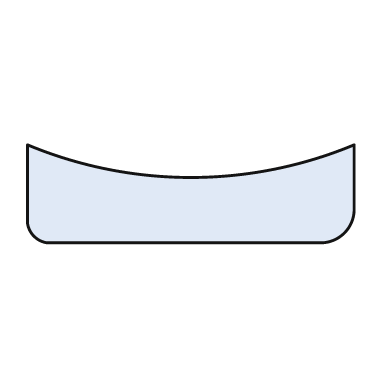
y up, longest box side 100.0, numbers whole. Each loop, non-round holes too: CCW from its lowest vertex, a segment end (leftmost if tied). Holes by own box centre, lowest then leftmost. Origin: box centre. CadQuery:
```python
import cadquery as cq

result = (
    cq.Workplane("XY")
    .moveTo(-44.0, -15.0)
    .lineTo(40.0, -15.0)
    .threePointArc((47.0, -12.0), (50.0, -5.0))
    .lineTo(50.0, 15.0)
    .threePointArc((0.0, 5.0), (-50.0, 15.0))
    .lineTo(-50.0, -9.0)
    .threePointArc((-48.0, -13.0), (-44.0, -15.0))
    .close()
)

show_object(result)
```